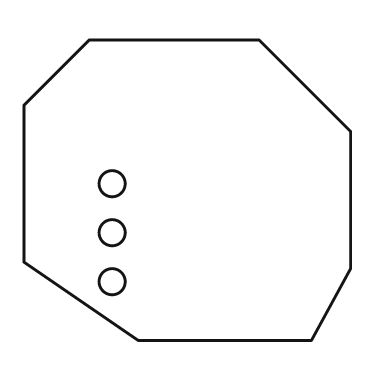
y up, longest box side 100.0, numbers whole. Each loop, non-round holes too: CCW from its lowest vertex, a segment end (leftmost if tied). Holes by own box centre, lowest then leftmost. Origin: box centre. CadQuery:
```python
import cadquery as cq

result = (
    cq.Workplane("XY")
    .moveTo(-15.0, -46.0)
    .lineTo(38.0, -46.0)
    .lineTo(50.0, -24.0)
    .lineTo(50.0, 18.0)
    .lineTo(22.0, 46.0)
    .lineTo(-30.0, 46.0)
    .lineTo(-50.0, 26.0)
    .lineTo(-50.0, -22.0)
    .close()
    .moveTo(-23.0, -28.0)
    .circle(4.0)
    .moveTo(-23.0, -13.0)
    .circle(4.0)
    .moveTo(-23.0, 2.0)
    .circle(4.0)
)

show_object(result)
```